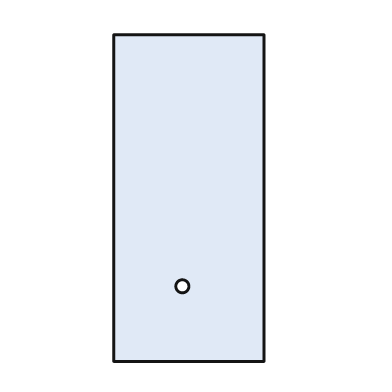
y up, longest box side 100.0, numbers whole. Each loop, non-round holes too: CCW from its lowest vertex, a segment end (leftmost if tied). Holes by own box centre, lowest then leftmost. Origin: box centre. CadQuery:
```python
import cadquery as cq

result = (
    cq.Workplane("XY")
    .moveTo(-23.0, -50.0)
    .lineTo(23.0, -50.0)
    .lineTo(23.0, 50.0)
    .lineTo(-23.0, 50.0)
    .close()
    .moveTo(-2.0, -27.0)
    .circle(2.0)
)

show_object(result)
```